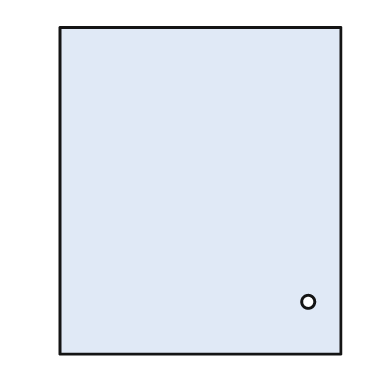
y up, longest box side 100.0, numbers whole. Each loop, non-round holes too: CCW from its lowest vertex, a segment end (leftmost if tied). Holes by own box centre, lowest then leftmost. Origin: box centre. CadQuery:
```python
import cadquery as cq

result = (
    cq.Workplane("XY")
    .moveTo(-43.0, -50.0)
    .lineTo(43.0, -50.0)
    .lineTo(43.0, 50.0)
    .lineTo(-43.0, 50.0)
    .close()
    .moveTo(33.0, -34.0)
    .circle(2.0)
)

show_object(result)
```